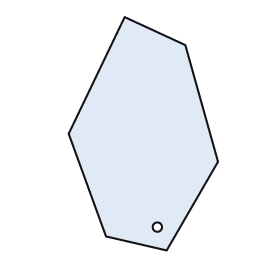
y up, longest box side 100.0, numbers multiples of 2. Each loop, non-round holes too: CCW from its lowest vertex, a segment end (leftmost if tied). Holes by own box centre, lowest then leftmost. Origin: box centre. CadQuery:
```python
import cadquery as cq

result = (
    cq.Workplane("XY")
    .moveTo(10.0, -50.0)
    .lineTo(32.0, -12.0)
    .lineTo(18.0, 38.0)
    .lineTo(-8.0, 50.0)
    .lineTo(-32.0, 0.0)
    .lineTo(-16.0, -44.0)
    .close()
    .moveTo(6.0, -40.0)
    .circle(2.0)
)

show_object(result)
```